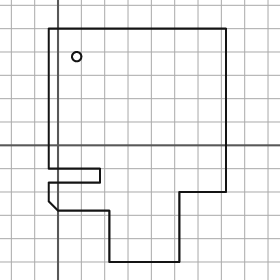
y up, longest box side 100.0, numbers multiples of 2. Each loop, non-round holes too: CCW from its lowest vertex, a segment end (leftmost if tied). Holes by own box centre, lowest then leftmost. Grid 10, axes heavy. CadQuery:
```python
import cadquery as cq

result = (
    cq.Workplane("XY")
    .moveTo(22.0, -50.0)
    .lineTo(52.0, -50.0)
    .lineTo(52.0, -20.0)
    .lineTo(72.0, -20.0)
    .lineTo(72.0, 50.0)
    .lineTo(-4.0, 50.0)
    .lineTo(-4.0, -10.0)
    .lineTo(18.0, -10.0)
    .lineTo(18.0, -16.0)
    .lineTo(-4.0, -16.0)
    .lineTo(-4.0, -24.0)
    .lineTo(0.0, -28.0)
    .lineTo(22.0, -28.0)
    .close()
    .moveTo(8.0, 38.0)
    .circle(2.0)
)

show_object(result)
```